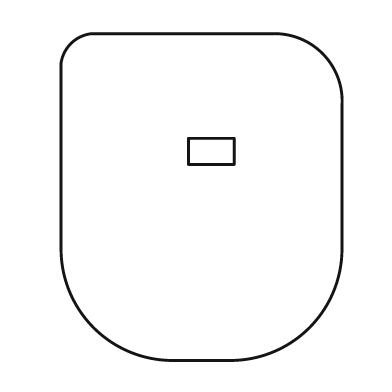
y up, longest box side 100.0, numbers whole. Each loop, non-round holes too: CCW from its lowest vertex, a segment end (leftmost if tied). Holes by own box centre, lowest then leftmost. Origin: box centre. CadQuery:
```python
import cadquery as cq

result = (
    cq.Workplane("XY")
    .moveTo(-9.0, -50.0)
    .lineTo(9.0, -50.0)
    .threePointArc((33.0, -40.0), (43.0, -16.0))
    .lineTo(43.0, 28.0)
    .threePointArc((37.0, 44.0), (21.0, 50.0))
    .lineTo(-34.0, 50.0)
    .threePointArc((-40.0, 47.0), (-43.0, 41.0))
    .lineTo(-43.0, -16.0)
    .threePointArc((-33.0, -40.0), (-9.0, -50.0))
    .close()
    .moveTo(-4.0, 10.0)
    .lineTo(10.0, 10.0)
    .lineTo(10.0, 18.0)
    .lineTo(-4.0, 18.0)
    .close()
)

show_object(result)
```